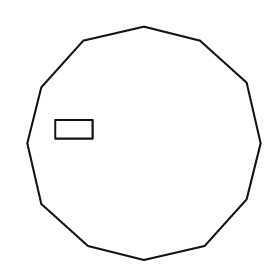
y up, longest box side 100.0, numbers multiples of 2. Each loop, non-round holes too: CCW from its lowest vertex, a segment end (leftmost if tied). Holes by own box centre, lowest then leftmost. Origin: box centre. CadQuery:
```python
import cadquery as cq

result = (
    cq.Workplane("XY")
    .moveTo(0.0, -50.0)
    .lineTo(26.0, -44.0)
    .lineTo(44.0, -24.0)
    .lineTo(50.0, 0.0)
    .lineTo(44.0, 26.0)
    .lineTo(24.0, 44.0)
    .lineTo(0.0, 50.0)
    .lineTo(-26.0, 44.0)
    .lineTo(-44.0, 24.0)
    .lineTo(-50.0, 0.0)
    .lineTo(-44.0, -26.0)
    .lineTo(-24.0, -44.0)
    .close()
    .moveTo(-38.0, 2.0)
    .lineTo(-22.0, 2.0)
    .lineTo(-22.0, 10.0)
    .lineTo(-38.0, 10.0)
    .close()
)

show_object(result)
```